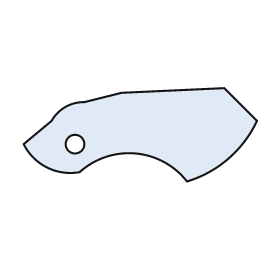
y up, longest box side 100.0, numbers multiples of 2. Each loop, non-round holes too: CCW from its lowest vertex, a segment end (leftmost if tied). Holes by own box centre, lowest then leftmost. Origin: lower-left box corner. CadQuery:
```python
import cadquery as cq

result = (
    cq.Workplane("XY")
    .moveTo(70.0, 0.0)
    .threePointArc((88.0, 10.0), (100.0, 26.0))
    .lineTo(86.0, 40.0)
    .lineTo(42.0, 38.0)
    .lineTo(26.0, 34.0)
    .threePointArc((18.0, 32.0), (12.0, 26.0))
    .lineTo(0.0, 16.0)
    .threePointArc((10.0, 6.0), (24.0, 4.0))
    .threePointArc((48.0, 12.0), (70.0, 0.0))
    .close()
    .moveTo(22.0, 16.0)
    .circle(4.0)
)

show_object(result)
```